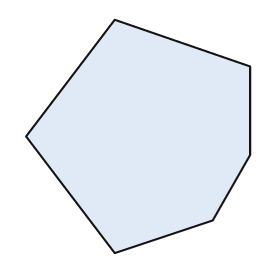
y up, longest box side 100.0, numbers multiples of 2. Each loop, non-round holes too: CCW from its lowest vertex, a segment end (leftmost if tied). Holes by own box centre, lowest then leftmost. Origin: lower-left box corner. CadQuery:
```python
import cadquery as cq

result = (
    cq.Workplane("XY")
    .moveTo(38.0, 0.0)
    .lineTo(80.0, 14.0)
    .lineTo(96.0, 42.0)
    .lineTo(96.0, 80.0)
    .lineTo(38.0, 100.0)
    .lineTo(0.0, 50.0)
    .close()
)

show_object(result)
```